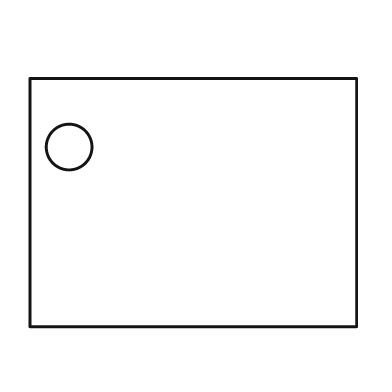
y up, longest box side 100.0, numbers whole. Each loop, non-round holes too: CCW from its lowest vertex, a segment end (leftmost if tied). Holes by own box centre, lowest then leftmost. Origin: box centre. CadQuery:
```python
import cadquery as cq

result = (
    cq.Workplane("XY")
    .moveTo(-50.0, -38.0)
    .lineTo(50.0, -38.0)
    .lineTo(50.0, 38.0)
    .lineTo(-50.0, 38.0)
    .close()
    .moveTo(-38.0, 17.0)
    .circle(7.0)
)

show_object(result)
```